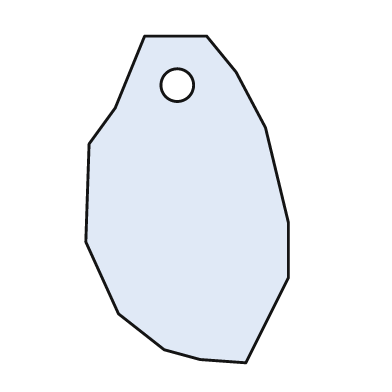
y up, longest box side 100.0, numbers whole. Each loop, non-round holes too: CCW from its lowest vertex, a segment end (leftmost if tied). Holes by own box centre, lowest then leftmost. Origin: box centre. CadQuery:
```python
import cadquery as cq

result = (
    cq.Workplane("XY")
    .moveTo(18.0, -50.0)
    .lineTo(31.0, -24.0)
    .lineTo(31.0, -7.0)
    .lineTo(24.0, 22.0)
    .lineTo(15.0, 39.0)
    .lineTo(6.0, 50.0)
    .lineTo(-13.0, 50.0)
    .lineTo(-22.0, 28.0)
    .lineTo(-30.0, 17.0)
    .lineTo(-31.0, -13.0)
    .lineTo(-21.0, -35.0)
    .lineTo(-7.0, -46.0)
    .lineTo(4.0, -49.0)
    .close()
    .moveTo(-3.0, 35.0)
    .circle(5.0)
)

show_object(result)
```